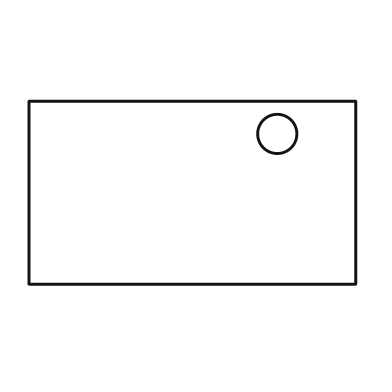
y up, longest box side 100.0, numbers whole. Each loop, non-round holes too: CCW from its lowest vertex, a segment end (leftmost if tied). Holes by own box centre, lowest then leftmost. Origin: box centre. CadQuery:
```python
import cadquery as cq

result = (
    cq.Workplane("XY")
    .moveTo(-50.0, -28.0)
    .lineTo(50.0, -28.0)
    .lineTo(50.0, 28.0)
    .lineTo(-50.0, 28.0)
    .close()
    .moveTo(26.0, 18.0)
    .circle(6.0)
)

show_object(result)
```